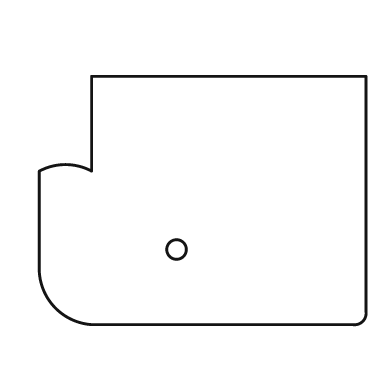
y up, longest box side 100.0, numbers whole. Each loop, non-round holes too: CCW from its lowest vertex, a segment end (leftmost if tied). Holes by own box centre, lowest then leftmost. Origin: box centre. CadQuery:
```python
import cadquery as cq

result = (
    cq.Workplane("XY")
    .moveTo(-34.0, -38.0)
    .lineTo(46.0, -38.0)
    .threePointArc((49.0, -37.0), (50.0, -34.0))
    .lineTo(50.0, 38.0)
    .lineTo(-34.0, 38.0)
    .lineTo(-34.0, 9.0)
    .threePointArc((-42.0, 11.0), (-50.0, 9.0))
    .lineTo(-50.0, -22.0)
    .threePointArc((-45.0, -33.0), (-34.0, -38.0))
    .close()
    .moveTo(-8.0, -15.0)
    .circle(3.0)
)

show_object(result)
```